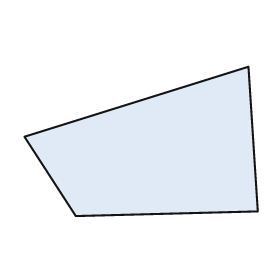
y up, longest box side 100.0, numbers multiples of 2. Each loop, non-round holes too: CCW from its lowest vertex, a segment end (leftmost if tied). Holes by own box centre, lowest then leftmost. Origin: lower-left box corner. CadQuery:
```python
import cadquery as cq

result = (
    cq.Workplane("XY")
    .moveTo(22.0, 0.0)
    .lineTo(100.0, 2.0)
    .lineTo(96.0, 64.0)
    .lineTo(0.0, 34.0)
    .close()
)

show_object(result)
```